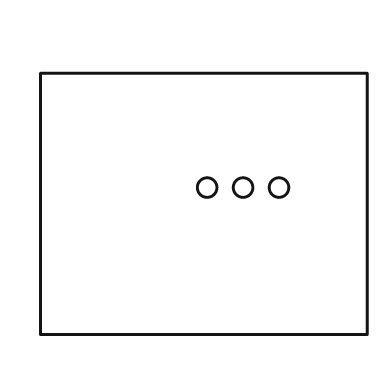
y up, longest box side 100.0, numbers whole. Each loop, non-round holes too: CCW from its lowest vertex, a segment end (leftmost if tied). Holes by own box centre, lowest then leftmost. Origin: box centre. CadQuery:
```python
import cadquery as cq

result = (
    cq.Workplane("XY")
    .moveTo(-50.0, -40.0)
    .lineTo(50.0, -40.0)
    .lineTo(50.0, 40.0)
    .lineTo(-50.0, 40.0)
    .close()
    .moveTo(1.0, 5.0)
    .circle(3.0)
    .moveTo(12.0, 5.0)
    .circle(3.0)
    .moveTo(23.0, 5.0)
    .circle(3.0)
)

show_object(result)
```